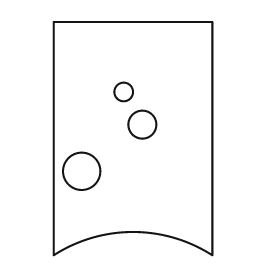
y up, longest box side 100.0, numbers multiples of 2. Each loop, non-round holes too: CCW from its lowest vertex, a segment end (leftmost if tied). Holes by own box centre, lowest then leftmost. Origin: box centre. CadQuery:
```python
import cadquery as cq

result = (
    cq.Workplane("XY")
    .moveTo(-34.0, -50.0)
    .threePointArc((0.0, -40.0), (34.0, -50.0))
    .lineTo(34.0, 50.0)
    .lineTo(-34.0, 50.0)
    .close()
    .moveTo(-22.0, -14.0)
    .circle(8.0)
    .moveTo(4.0, 6.0)
    .circle(6.0)
    .moveTo(-4.0, 20.0)
    .circle(4.0)
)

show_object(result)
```